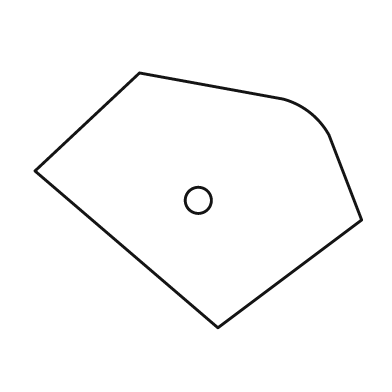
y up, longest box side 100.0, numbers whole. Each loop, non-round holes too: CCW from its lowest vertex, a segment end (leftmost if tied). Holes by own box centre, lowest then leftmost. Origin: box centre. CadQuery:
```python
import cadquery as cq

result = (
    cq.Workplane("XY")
    .moveTo(6.0, -39.0)
    .lineTo(50.0, -6.0)
    .lineTo(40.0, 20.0)
    .threePointArc((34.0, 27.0), (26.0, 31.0))
    .lineTo(-18.0, 39.0)
    .lineTo(-50.0, 9.0)
    .close()
    .moveTo(0.0, 0.0)
    .circle(4.0)
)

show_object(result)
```